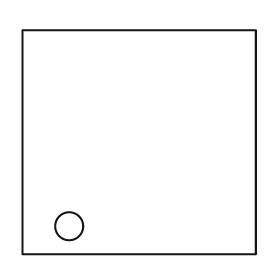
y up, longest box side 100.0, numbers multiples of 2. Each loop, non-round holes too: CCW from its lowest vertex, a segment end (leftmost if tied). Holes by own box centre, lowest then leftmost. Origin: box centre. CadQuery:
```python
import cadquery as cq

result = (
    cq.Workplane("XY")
    .moveTo(-50.0, -48.0)
    .lineTo(50.0, -48.0)
    .lineTo(50.0, 48.0)
    .lineTo(-50.0, 48.0)
    .close()
    .moveTo(-30.0, -36.0)
    .circle(6.0)
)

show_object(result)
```